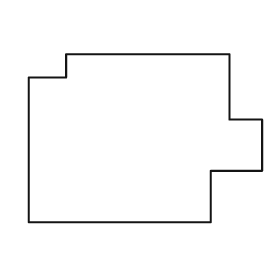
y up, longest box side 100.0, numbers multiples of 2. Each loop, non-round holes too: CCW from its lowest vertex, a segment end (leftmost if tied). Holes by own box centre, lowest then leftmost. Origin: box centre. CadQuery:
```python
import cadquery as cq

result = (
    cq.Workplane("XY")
    .moveTo(-50.0, -36.0)
    .lineTo(28.0, -36.0)
    .lineTo(28.0, -14.0)
    .lineTo(50.0, -14.0)
    .lineTo(50.0, 8.0)
    .lineTo(36.0, 8.0)
    .lineTo(36.0, 36.0)
    .lineTo(-34.0, 36.0)
    .lineTo(-34.0, 26.0)
    .lineTo(-50.0, 26.0)
    .close()
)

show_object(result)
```